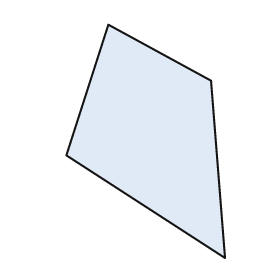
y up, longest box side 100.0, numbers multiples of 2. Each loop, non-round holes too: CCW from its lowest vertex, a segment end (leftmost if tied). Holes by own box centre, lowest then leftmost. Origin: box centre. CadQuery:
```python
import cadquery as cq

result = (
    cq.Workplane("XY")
    .moveTo(34.0, -50.0)
    .lineTo(28.0, 26.0)
    .lineTo(-16.0, 50.0)
    .lineTo(-34.0, -6.0)
    .close()
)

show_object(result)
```